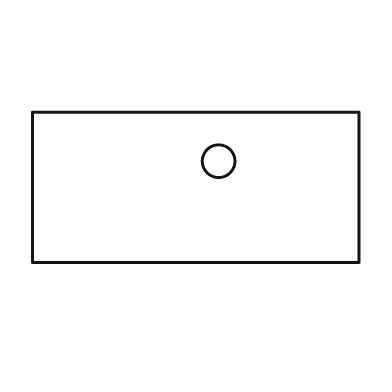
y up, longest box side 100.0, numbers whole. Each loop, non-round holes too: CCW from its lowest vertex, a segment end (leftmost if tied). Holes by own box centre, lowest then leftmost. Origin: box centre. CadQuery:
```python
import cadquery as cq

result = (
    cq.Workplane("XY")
    .moveTo(-50.0, -23.0)
    .lineTo(50.0, -23.0)
    .lineTo(50.0, 23.0)
    .lineTo(-50.0, 23.0)
    .close()
    .moveTo(7.0, 8.0)
    .circle(5.0)
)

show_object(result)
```